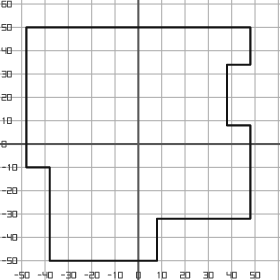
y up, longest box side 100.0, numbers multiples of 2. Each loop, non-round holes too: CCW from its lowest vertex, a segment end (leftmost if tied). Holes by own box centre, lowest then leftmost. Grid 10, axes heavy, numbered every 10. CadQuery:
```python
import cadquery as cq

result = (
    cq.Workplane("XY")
    .moveTo(-38.0, -50.0)
    .lineTo(8.0, -50.0)
    .lineTo(8.0, -32.0)
    .lineTo(48.0, -32.0)
    .lineTo(48.0, 8.0)
    .lineTo(38.0, 8.0)
    .lineTo(38.0, 34.0)
    .lineTo(48.0, 34.0)
    .lineTo(48.0, 50.0)
    .lineTo(-48.0, 50.0)
    .lineTo(-48.0, -10.0)
    .lineTo(-38.0, -10.0)
    .close()
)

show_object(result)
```